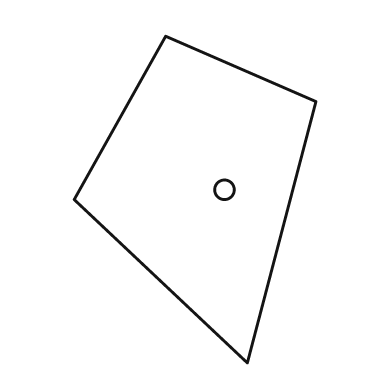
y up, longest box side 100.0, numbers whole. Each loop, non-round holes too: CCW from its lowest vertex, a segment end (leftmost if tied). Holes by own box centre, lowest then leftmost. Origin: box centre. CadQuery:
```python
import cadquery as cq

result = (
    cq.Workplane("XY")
    .moveTo(16.0, -50.0)
    .lineTo(37.0, 30.0)
    .lineTo(-9.0, 50.0)
    .lineTo(-37.0, 0.0)
    .close()
    .moveTo(9.0, 3.0)
    .circle(3.0)
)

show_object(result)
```